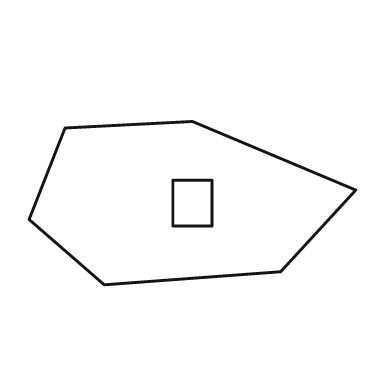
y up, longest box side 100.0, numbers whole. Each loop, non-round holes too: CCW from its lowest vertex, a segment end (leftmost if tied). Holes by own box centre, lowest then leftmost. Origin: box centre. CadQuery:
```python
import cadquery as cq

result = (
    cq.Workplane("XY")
    .moveTo(-27.0, -25.0)
    .lineTo(27.0, -21.0)
    .lineTo(50.0, 4.0)
    .lineTo(0.0, 25.0)
    .lineTo(-39.0, 23.0)
    .lineTo(-50.0, -5.0)
    .close()
    .moveTo(-6.0, -7.0)
    .lineTo(6.0, -7.0)
    .lineTo(6.0, 7.0)
    .lineTo(-6.0, 7.0)
    .close()
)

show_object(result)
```